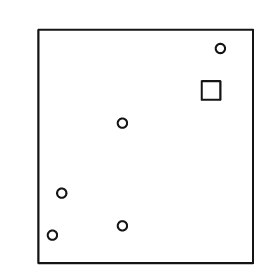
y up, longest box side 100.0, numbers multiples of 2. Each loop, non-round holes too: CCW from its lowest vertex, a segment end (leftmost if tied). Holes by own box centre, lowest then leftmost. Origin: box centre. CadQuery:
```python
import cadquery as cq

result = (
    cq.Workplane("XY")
    .moveTo(-46.0, -50.0)
    .lineTo(46.0, -50.0)
    .lineTo(46.0, 50.0)
    .lineTo(-46.0, 50.0)
    .close()
    .moveTo(-40.0, -38.0)
    .circle(2.0)
    .moveTo(-10.0, -34.0)
    .circle(2.0)
    .moveTo(-36.0, -20.0)
    .circle(2.0)
    .moveTo(-10.0, 10.0)
    .circle(2.0)
    .moveTo(24.0, 20.0)
    .lineTo(32.0, 20.0)
    .lineTo(32.0, 28.0)
    .lineTo(24.0, 28.0)
    .close()
    .moveTo(32.0, 42.0)
    .circle(2.0)
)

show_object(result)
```